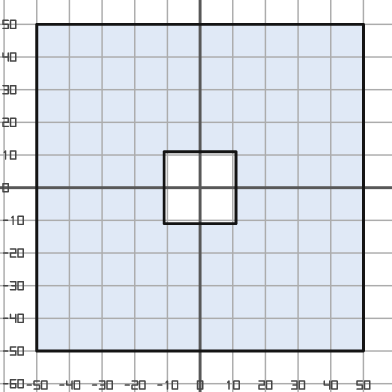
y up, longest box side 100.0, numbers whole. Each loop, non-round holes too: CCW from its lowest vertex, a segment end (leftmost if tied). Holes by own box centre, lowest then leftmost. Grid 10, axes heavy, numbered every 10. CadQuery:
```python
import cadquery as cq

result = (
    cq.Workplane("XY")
    .moveTo(-50.0, -50.0)
    .lineTo(50.0, -50.0)
    .lineTo(50.0, 50.0)
    .lineTo(-50.0, 50.0)
    .close()
    .moveTo(-11.0, -11.0)
    .lineTo(11.0, -11.0)
    .lineTo(11.0, 11.0)
    .lineTo(-11.0, 11.0)
    .close()
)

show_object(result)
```